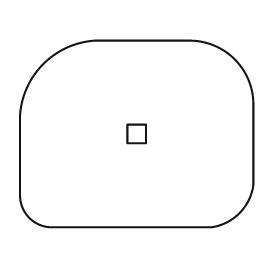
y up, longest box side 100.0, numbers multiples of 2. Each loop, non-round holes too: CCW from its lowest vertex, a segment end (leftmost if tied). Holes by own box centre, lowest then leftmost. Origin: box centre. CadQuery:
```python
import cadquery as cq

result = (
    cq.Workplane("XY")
    .moveTo(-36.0, -40.0)
    .lineTo(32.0, -40.0)
    .threePointArc((44.0, -34.0), (50.0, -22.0))
    .lineTo(50.0, 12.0)
    .threePointArc((42.0, 32.0), (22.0, 40.0))
    .lineTo(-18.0, 40.0)
    .threePointArc((-40.0, 30.0), (-50.0, 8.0))
    .lineTo(-50.0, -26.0)
    .threePointArc((-46.0, -36.0), (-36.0, -40.0))
    .close()
    .moveTo(-4.0, -4.0)
    .lineTo(4.0, -4.0)
    .lineTo(4.0, 4.0)
    .lineTo(-4.0, 4.0)
    .close()
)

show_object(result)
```